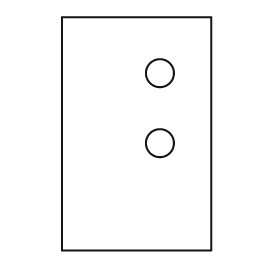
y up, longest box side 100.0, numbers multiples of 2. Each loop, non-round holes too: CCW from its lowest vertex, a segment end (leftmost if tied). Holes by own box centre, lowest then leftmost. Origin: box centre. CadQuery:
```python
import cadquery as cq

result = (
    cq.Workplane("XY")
    .moveTo(-32.0, -50.0)
    .lineTo(32.0, -50.0)
    .lineTo(32.0, 50.0)
    .lineTo(-32.0, 50.0)
    .close()
    .moveTo(10.0, -4.0)
    .circle(6.0)
    .moveTo(10.0, 26.0)
    .circle(6.0)
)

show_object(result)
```